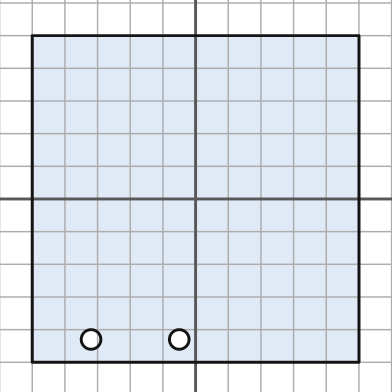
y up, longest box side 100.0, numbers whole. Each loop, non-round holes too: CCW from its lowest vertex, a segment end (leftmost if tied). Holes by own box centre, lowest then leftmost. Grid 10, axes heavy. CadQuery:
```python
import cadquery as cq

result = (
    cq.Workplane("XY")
    .moveTo(-50.0, -50.0)
    .lineTo(50.0, -50.0)
    .lineTo(50.0, 50.0)
    .lineTo(-50.0, 50.0)
    .close()
    .moveTo(-32.0, -43.0)
    .circle(3.0)
    .moveTo(-5.0, -43.0)
    .circle(3.0)
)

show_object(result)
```